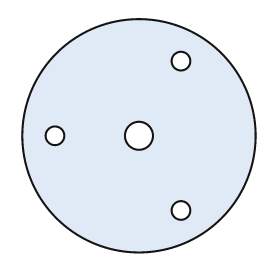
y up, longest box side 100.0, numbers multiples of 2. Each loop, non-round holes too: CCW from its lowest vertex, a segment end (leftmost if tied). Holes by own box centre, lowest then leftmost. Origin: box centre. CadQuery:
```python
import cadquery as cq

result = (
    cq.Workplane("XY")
    .moveTo(0.0, 0.0)
    .circle(50.0)
    .moveTo(18.0, -32.0)
    .circle(4.0)
    .moveTo(-36.0, 0.0)
    .circle(4.0)
    .moveTo(0.0, 0.0)
    .circle(6.0)
    .moveTo(18.0, 32.0)
    .circle(4.0)
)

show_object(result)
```